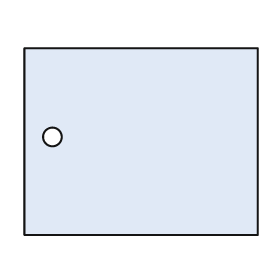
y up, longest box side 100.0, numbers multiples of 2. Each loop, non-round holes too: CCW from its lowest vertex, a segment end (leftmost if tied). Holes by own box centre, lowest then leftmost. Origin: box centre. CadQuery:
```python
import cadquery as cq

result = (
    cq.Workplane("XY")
    .moveTo(-50.0, -40.0)
    .lineTo(50.0, -40.0)
    .lineTo(50.0, 40.0)
    .lineTo(-50.0, 40.0)
    .close()
    .moveTo(-38.0, 2.0)
    .circle(4.0)
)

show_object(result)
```